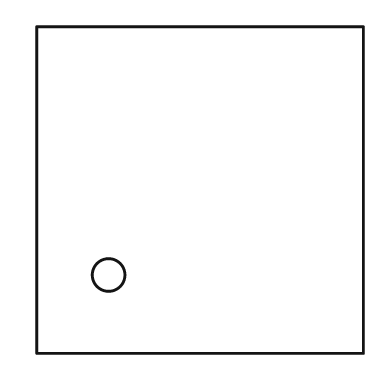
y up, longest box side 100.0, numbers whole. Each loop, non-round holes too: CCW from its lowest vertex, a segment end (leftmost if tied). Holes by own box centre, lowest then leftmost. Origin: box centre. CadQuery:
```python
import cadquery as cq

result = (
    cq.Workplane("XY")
    .moveTo(-50.0, -50.0)
    .lineTo(50.0, -50.0)
    .lineTo(50.0, 50.0)
    .lineTo(-50.0, 50.0)
    .close()
    .moveTo(-28.0, -26.0)
    .circle(5.0)
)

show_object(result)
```